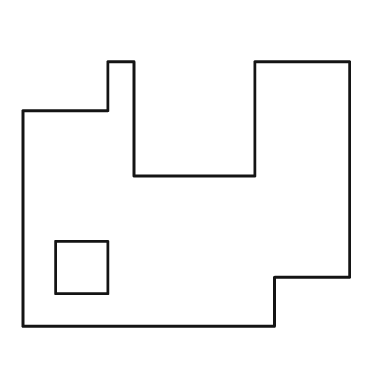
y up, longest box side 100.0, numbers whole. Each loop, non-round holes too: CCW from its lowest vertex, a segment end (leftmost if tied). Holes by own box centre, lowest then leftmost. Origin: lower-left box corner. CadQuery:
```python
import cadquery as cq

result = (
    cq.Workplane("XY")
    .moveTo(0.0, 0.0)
    .lineTo(77.0, 0.0)
    .lineTo(77.0, 15.0)
    .lineTo(100.0, 15.0)
    .lineTo(100.0, 81.0)
    .lineTo(71.0, 81.0)
    .lineTo(71.0, 46.0)
    .lineTo(34.0, 46.0)
    .lineTo(34.0, 81.0)
    .lineTo(26.0, 81.0)
    .lineTo(26.0, 66.0)
    .lineTo(0.0, 66.0)
    .close()
    .moveTo(10.0, 10.0)
    .lineTo(26.0, 10.0)
    .lineTo(26.0, 26.0)
    .lineTo(10.0, 26.0)
    .close()
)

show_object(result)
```